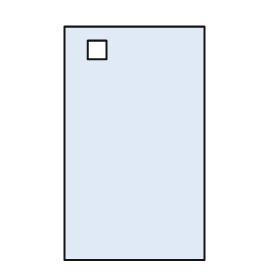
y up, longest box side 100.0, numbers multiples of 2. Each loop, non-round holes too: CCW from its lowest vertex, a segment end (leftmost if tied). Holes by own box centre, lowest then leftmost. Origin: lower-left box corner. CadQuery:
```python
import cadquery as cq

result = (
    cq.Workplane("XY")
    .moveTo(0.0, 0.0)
    .lineTo(60.0, 0.0)
    .lineTo(60.0, 100.0)
    .lineTo(0.0, 100.0)
    .close()
    .moveTo(10.0, 86.0)
    .lineTo(18.0, 86.0)
    .lineTo(18.0, 94.0)
    .lineTo(10.0, 94.0)
    .close()
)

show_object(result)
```